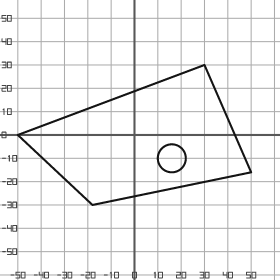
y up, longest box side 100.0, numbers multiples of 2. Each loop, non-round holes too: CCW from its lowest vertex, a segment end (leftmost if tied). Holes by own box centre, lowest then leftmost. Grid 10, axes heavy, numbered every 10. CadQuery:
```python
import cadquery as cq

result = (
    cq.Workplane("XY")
    .moveTo(-18.0, -30.0)
    .lineTo(50.0, -16.0)
    .lineTo(30.0, 30.0)
    .lineTo(-50.0, 0.0)
    .close()
    .moveTo(16.0, -10.0)
    .circle(6.0)
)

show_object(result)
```